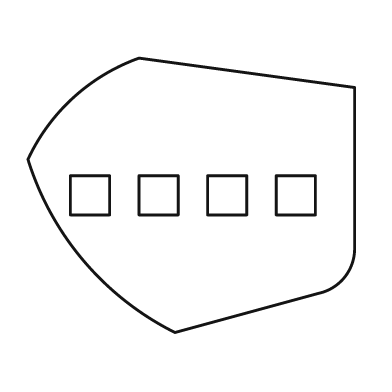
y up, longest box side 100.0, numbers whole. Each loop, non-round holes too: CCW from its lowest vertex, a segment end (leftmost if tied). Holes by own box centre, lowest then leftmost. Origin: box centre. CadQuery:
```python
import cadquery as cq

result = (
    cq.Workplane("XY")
    .moveTo(-5.0, -42.0)
    .lineTo(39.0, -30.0)
    .threePointArc((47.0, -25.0), (50.0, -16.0))
    .lineTo(50.0, 33.0)
    .lineTo(-16.0, 42.0)
    .threePointArc((-36.0, 30.0), (-50.0, 11.0))
    .threePointArc((-33.0, -20.0), (-5.0, -42.0))
    .close()
    .moveTo(-37.0, -6.0)
    .lineTo(-25.0, -6.0)
    .lineTo(-25.0, 6.0)
    .lineTo(-37.0, 6.0)
    .close()
    .moveTo(-16.0, -6.0)
    .lineTo(-4.0, -6.0)
    .lineTo(-4.0, 6.0)
    .lineTo(-16.0, 6.0)
    .close()
    .moveTo(5.0, -6.0)
    .lineTo(17.0, -6.0)
    .lineTo(17.0, 6.0)
    .lineTo(5.0, 6.0)
    .close()
    .moveTo(26.0, -6.0)
    .lineTo(38.0, -6.0)
    .lineTo(38.0, 6.0)
    .lineTo(26.0, 6.0)
    .close()
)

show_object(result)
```